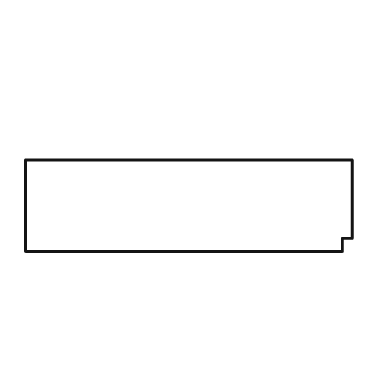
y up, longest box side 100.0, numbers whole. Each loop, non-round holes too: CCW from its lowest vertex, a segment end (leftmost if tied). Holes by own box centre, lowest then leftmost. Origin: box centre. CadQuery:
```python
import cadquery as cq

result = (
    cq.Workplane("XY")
    .moveTo(-50.0, -14.0)
    .lineTo(47.0, -14.0)
    .lineTo(47.0, -10.0)
    .lineTo(50.0, -10.0)
    .lineTo(50.0, 14.0)
    .lineTo(-50.0, 14.0)
    .close()
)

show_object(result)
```